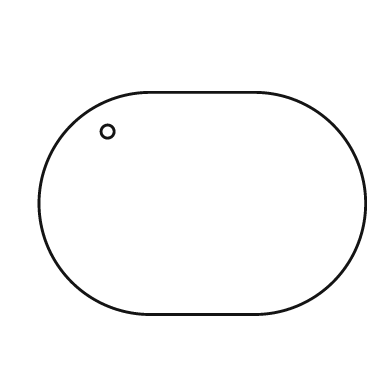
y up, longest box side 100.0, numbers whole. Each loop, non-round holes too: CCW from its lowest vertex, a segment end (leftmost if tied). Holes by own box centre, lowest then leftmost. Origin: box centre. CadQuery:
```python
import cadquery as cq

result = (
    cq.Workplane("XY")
    .moveTo(-16.0, -34.0)
    .lineTo(16.0, -34.0)
    .threePointArc((50.0, 0.0), (16.0, 34.0))
    .lineTo(-16.0, 34.0)
    .threePointArc((-50.0, 0.0), (-16.0, -34.0))
    .close()
    .moveTo(-29.0, 22.0)
    .circle(2.0)
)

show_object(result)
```